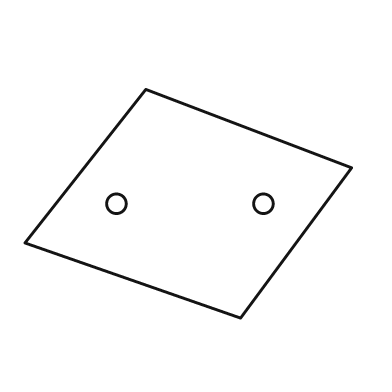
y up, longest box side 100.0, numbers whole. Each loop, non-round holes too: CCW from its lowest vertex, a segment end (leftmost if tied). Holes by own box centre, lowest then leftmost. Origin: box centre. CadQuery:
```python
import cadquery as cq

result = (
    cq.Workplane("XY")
    .moveTo(16.0, -35.0)
    .lineTo(50.0, 11.0)
    .lineTo(-13.0, 35.0)
    .lineTo(-50.0, -12.0)
    .close()
    .moveTo(-22.0, 0.0)
    .circle(3.0)
    .moveTo(23.0, 0.0)
    .circle(3.0)
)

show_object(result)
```